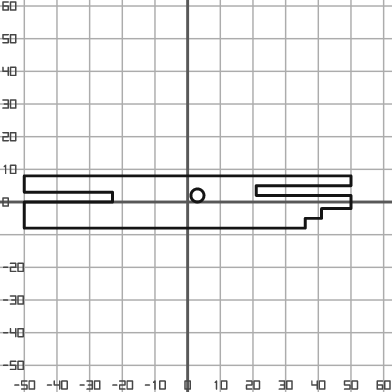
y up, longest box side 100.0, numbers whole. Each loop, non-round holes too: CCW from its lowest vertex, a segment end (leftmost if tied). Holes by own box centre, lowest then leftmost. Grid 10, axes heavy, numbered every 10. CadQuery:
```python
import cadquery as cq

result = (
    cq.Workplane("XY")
    .moveTo(-50.0, -8.0)
    .lineTo(36.0, -8.0)
    .lineTo(36.0, -5.0)
    .lineTo(41.0, -5.0)
    .lineTo(41.0, -2.0)
    .lineTo(50.0, -2.0)
    .lineTo(50.0, 2.0)
    .lineTo(21.0, 2.0)
    .lineTo(21.0, 5.0)
    .lineTo(50.0, 5.0)
    .lineTo(50.0, 8.0)
    .lineTo(-50.0, 8.0)
    .lineTo(-50.0, 3.0)
    .lineTo(-23.0, 3.0)
    .lineTo(-23.0, 0.0)
    .lineTo(-50.0, 0.0)
    .close()
    .moveTo(3.0, 2.0)
    .circle(2.0)
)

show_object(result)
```